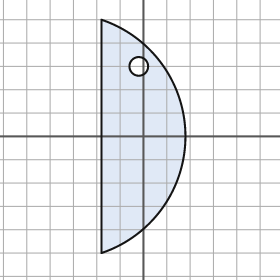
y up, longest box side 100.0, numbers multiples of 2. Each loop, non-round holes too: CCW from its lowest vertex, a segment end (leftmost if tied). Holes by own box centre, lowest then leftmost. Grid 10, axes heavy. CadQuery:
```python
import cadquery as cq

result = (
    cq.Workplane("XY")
    .moveTo(-18.0, -50.0)
    .threePointArc((18.0, 0.0), (-18.0, 50.0))
    .close()
    .moveTo(-2.0, 30.0)
    .circle(4.0)
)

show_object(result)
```